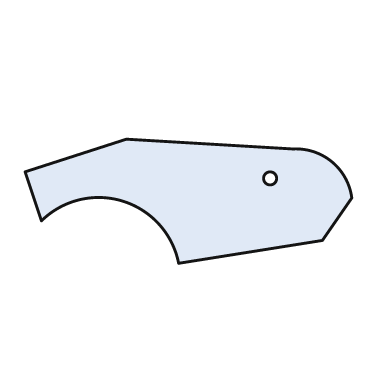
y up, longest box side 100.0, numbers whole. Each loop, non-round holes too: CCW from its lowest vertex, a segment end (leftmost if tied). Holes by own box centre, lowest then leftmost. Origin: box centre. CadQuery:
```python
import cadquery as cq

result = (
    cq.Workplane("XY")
    .moveTo(-3.0, -19.0)
    .lineTo(41.0, -12.0)
    .lineTo(50.0, 1.0)
    .threePointArc((44.0, 12.0), (32.0, 16.0))
    .lineTo(-19.0, 19.0)
    .lineTo(-50.0, 9.0)
    .lineTo(-45.0, -6.0)
    .threePointArc((-20.0, 0.0), (-3.0, -19.0))
    .close()
    .moveTo(25.0, 7.0)
    .circle(2.0)
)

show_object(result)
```